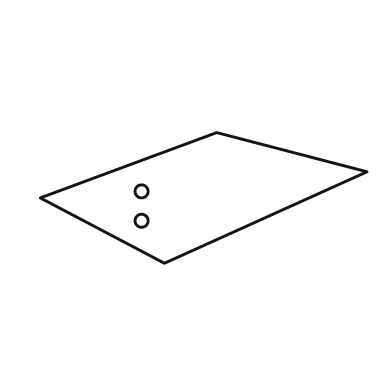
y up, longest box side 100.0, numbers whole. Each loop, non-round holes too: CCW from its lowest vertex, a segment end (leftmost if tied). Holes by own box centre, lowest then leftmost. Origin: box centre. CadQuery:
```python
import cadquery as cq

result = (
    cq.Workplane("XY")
    .moveTo(-12.0, -20.0)
    .lineTo(50.0, 8.0)
    .lineTo(4.0, 20.0)
    .lineTo(-50.0, 0.0)
    .close()
    .moveTo(-19.0, -7.0)
    .circle(2.0)
    .moveTo(-19.0, 2.0)
    .circle(2.0)
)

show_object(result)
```